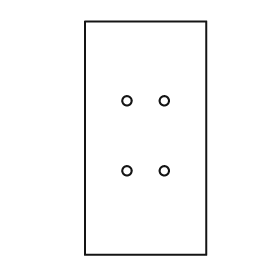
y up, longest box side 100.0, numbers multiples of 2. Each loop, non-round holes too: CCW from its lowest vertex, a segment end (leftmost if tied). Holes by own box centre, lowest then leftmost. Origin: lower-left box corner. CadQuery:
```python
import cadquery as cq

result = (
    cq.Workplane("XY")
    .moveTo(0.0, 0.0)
    .lineTo(52.0, 0.0)
    .lineTo(52.0, 100.0)
    .lineTo(0.0, 100.0)
    .close()
    .moveTo(18.0, 36.0)
    .circle(2.0)
    .moveTo(34.0, 36.0)
    .circle(2.0)
    .moveTo(18.0, 66.0)
    .circle(2.0)
    .moveTo(34.0, 66.0)
    .circle(2.0)
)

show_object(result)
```